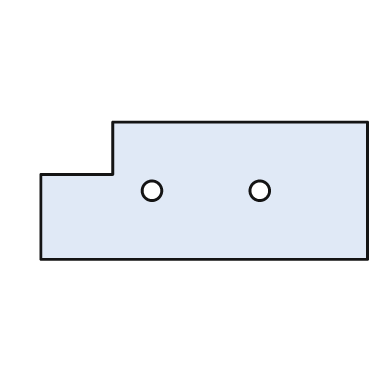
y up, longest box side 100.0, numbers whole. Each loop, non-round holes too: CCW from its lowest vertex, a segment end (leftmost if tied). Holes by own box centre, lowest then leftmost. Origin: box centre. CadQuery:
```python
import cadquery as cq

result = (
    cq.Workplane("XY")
    .moveTo(-50.0, -21.0)
    .lineTo(50.0, -21.0)
    .lineTo(50.0, 21.0)
    .lineTo(-28.0, 21.0)
    .lineTo(-28.0, 5.0)
    .lineTo(-50.0, 5.0)
    .close()
    .moveTo(-16.0, 0.0)
    .circle(3.0)
    .moveTo(17.0, 0.0)
    .circle(3.0)
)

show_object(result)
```